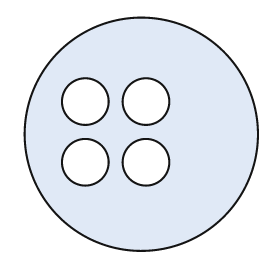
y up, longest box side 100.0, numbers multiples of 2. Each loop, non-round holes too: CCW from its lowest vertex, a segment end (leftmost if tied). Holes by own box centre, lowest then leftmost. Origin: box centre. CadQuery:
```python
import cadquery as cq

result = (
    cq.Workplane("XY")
    .moveTo(0.0, 0.0)
    .circle(50.0)
    .moveTo(-24.0, -12.0)
    .circle(10.0)
    .moveTo(2.0, -12.0)
    .circle(10.0)
    .moveTo(-24.0, 14.0)
    .circle(10.0)
    .moveTo(2.0, 14.0)
    .circle(10.0)
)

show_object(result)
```